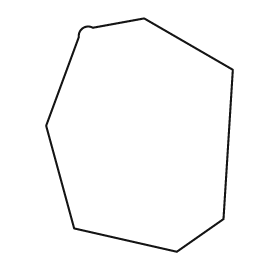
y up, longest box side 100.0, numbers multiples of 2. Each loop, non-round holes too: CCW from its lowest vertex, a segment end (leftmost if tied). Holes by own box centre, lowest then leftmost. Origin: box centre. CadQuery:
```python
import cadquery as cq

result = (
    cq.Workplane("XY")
    .moveTo(16.0, -50.0)
    .lineTo(36.0, -36.0)
    .lineTo(40.0, 28.0)
    .lineTo(2.0, 50.0)
    .lineTo(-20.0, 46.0)
    .threePointArc((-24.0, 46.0), (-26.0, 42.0))
    .lineTo(-40.0, 4.0)
    .lineTo(-28.0, -40.0)
    .close()
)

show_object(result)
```